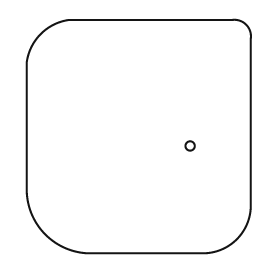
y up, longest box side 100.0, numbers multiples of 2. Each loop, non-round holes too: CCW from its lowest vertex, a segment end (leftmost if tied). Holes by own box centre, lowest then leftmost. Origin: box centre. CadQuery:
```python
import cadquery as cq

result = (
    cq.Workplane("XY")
    .moveTo(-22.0, -50.0)
    .lineTo(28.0, -50.0)
    .threePointArc((42.0, -44.0), (48.0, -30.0))
    .lineTo(48.0, 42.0)
    .threePointArc((46.0, 48.0), (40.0, 50.0))
    .lineTo(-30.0, 50.0)
    .threePointArc((-42.0, 44.0), (-48.0, 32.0))
    .lineTo(-48.0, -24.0)
    .threePointArc((-40.0, -42.0), (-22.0, -50.0))
    .close()
    .moveTo(22.0, -4.0)
    .circle(2.0)
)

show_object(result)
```